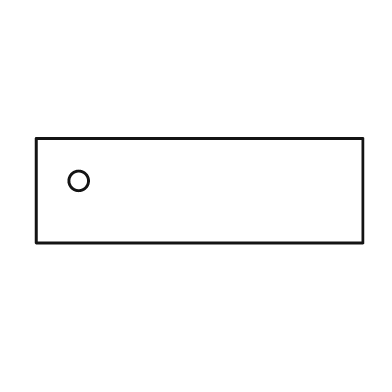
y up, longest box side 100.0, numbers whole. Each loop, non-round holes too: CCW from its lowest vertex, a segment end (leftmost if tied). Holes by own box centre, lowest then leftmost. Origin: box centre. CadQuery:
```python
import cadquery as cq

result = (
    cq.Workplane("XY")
    .moveTo(-50.0, -16.0)
    .lineTo(50.0, -16.0)
    .lineTo(50.0, 16.0)
    .lineTo(-50.0, 16.0)
    .close()
    .moveTo(-37.0, 3.0)
    .circle(3.0)
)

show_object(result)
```